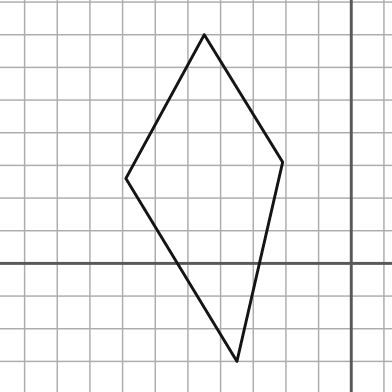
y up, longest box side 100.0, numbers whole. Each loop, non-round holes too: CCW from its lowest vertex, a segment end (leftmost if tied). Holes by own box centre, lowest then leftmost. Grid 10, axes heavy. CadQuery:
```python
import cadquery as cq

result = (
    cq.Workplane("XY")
    .moveTo(-35.0, -30.0)
    .lineTo(-21.0, 31.0)
    .lineTo(-45.0, 70.0)
    .lineTo(-69.0, 26.0)
    .close()
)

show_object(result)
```